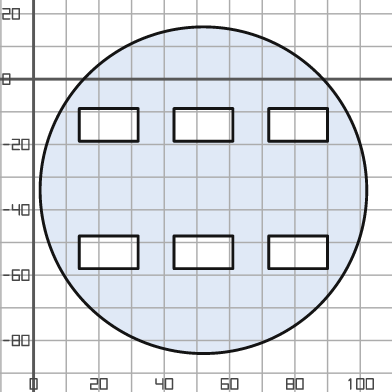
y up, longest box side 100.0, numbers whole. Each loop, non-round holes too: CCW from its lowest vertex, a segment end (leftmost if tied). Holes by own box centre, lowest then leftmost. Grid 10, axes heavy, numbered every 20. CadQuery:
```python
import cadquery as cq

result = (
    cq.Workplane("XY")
    .moveTo(52.0, -34.0)
    .circle(50.0)
    .moveTo(14.0, -58.0)
    .lineTo(32.0, -58.0)
    .lineTo(32.0, -48.0)
    .lineTo(14.0, -48.0)
    .close()
    .moveTo(43.0, -58.0)
    .lineTo(61.0, -58.0)
    .lineTo(61.0, -48.0)
    .lineTo(43.0, -48.0)
    .close()
    .moveTo(72.0, -58.0)
    .lineTo(90.0, -58.0)
    .lineTo(90.0, -48.0)
    .lineTo(72.0, -48.0)
    .close()
    .moveTo(14.0, -19.0)
    .lineTo(32.0, -19.0)
    .lineTo(32.0, -9.0)
    .lineTo(14.0, -9.0)
    .close()
    .moveTo(43.0, -19.0)
    .lineTo(61.0, -19.0)
    .lineTo(61.0, -9.0)
    .lineTo(43.0, -9.0)
    .close()
    .moveTo(72.0, -19.0)
    .lineTo(90.0, -19.0)
    .lineTo(90.0, -9.0)
    .lineTo(72.0, -9.0)
    .close()
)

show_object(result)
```